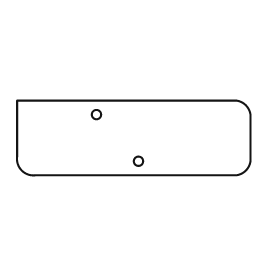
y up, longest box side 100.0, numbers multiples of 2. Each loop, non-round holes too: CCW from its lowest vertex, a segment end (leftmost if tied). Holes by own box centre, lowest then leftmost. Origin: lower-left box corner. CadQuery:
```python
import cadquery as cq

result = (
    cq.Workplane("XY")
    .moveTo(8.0, 0.0)
    .lineTo(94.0, 0.0)
    .threePointArc((98.0, 2.0), (100.0, 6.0))
    .lineTo(100.0, 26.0)
    .threePointArc((98.0, 30.0), (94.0, 32.0))
    .lineTo(0.0, 32.0)
    .lineTo(0.0, 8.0)
    .threePointArc((2.0, 2.0), (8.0, 0.0))
    .close()
    .moveTo(52.0, 6.0)
    .circle(2.0)
    .moveTo(34.0, 26.0)
    .circle(2.0)
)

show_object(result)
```